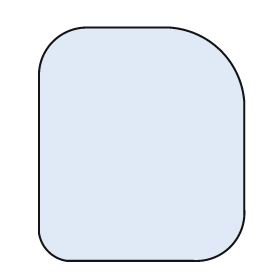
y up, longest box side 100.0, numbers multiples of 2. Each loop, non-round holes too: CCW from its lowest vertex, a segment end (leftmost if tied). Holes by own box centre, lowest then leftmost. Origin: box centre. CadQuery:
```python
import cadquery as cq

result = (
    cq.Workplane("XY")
    .moveTo(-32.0, -50.0)
    .lineTo(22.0, -50.0)
    .threePointArc((38.0, -44.0), (44.0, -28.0))
    .lineTo(44.0, 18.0)
    .threePointArc((34.0, 40.0), (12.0, 50.0))
    .lineTo(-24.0, 50.0)
    .threePointArc((-38.0, 44.0), (-44.0, 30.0))
    .lineTo(-44.0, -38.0)
    .threePointArc((-40.0, -46.0), (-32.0, -50.0))
    .close()
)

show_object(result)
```